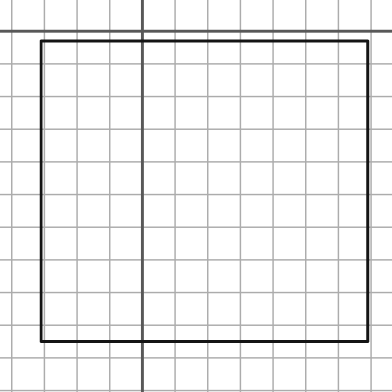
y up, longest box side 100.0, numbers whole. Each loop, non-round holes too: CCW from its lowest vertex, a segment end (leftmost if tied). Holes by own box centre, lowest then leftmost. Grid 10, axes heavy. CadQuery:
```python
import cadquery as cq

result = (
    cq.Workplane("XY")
    .moveTo(-31.0, -95.0)
    .lineTo(69.0, -95.0)
    .lineTo(69.0, -3.0)
    .lineTo(-31.0, -3.0)
    .close()
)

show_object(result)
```